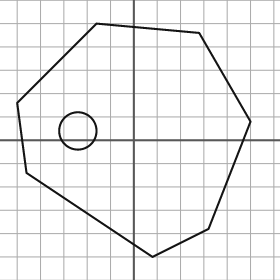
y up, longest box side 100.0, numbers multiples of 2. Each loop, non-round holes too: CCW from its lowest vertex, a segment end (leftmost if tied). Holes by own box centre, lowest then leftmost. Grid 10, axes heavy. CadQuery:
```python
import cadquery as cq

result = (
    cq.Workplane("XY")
    .moveTo(8.0, -50.0)
    .lineTo(32.0, -38.0)
    .lineTo(50.0, 8.0)
    .lineTo(28.0, 46.0)
    .lineTo(-16.0, 50.0)
    .lineTo(-50.0, 16.0)
    .lineTo(-46.0, -14.0)
    .close()
    .moveTo(-24.0, 4.0)
    .circle(8.0)
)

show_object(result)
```